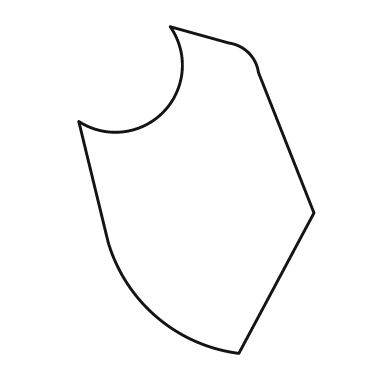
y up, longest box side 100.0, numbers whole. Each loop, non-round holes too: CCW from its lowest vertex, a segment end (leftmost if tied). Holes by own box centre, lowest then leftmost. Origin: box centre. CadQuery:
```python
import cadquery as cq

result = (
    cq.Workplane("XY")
    .moveTo(13.0, -50.0)
    .lineTo(36.0, -7.0)
    .lineTo(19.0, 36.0)
    .threePointArc((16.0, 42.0), (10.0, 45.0))
    .lineTo(-8.0, 50.0)
    .threePointArc((-10.0, 24.0), (-36.0, 21.0))
    .lineTo(-27.0, -16.0)
    .threePointArc((-12.0, -39.0), (13.0, -50.0))
    .close()
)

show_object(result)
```